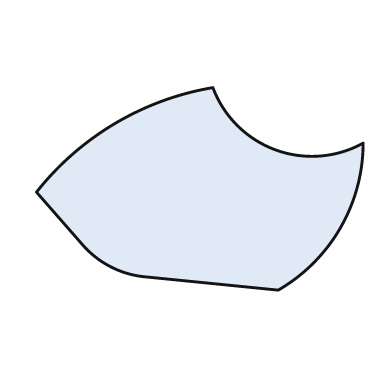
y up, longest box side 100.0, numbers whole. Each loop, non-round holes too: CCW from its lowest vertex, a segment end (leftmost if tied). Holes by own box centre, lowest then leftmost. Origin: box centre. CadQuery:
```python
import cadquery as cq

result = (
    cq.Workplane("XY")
    .moveTo(24.0, -31.0)
    .threePointArc((43.0, -12.0), (50.0, 14.0))
    .threePointArc((23.0, 12.0), (4.0, 31.0))
    .threePointArc((-26.0, 20.0), (-50.0, -1.0))
    .lineTo(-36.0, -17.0)
    .threePointArc((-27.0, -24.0), (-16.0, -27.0))
    .close()
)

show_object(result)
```